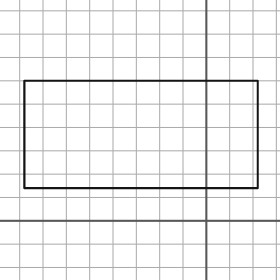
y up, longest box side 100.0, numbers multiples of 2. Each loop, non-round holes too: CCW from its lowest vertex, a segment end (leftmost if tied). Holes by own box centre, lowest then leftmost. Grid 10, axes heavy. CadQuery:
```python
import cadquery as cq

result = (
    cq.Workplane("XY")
    .moveTo(-78.0, 14.0)
    .lineTo(22.0, 14.0)
    .lineTo(22.0, 60.0)
    .lineTo(-78.0, 60.0)
    .close()
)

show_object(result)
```